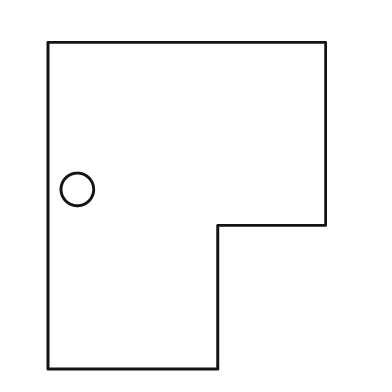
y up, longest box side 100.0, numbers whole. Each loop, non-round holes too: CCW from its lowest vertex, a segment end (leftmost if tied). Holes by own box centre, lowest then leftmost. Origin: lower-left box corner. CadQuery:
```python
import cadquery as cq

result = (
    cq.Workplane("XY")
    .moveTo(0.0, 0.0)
    .lineTo(52.0, 0.0)
    .lineTo(52.0, 44.0)
    .lineTo(85.0, 44.0)
    .lineTo(85.0, 100.0)
    .lineTo(0.0, 100.0)
    .close()
    .moveTo(9.0, 55.0)
    .circle(5.0)
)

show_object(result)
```